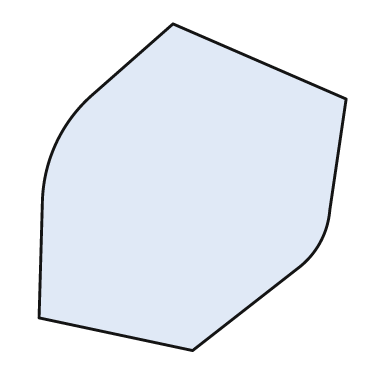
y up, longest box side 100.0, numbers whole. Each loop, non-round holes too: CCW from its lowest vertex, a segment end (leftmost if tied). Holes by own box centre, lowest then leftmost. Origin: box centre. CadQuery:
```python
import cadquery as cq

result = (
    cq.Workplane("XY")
    .moveTo(0.0, -50.0)
    .lineTo(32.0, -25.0)
    .threePointArc((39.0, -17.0), (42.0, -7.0))
    .lineTo(47.0, 27.0)
    .lineTo(-6.0, 50.0)
    .lineTo(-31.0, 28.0)
    .threePointArc((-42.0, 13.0), (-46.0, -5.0))
    .lineTo(-47.0, -40.0)
    .close()
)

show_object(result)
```